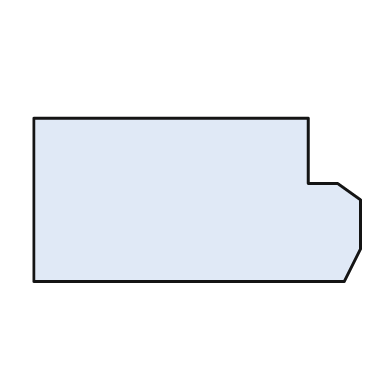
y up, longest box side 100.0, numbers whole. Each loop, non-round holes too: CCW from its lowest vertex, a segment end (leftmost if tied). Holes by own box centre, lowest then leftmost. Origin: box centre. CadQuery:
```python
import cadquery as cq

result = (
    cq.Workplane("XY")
    .moveTo(-50.0, -25.0)
    .lineTo(45.0, -25.0)
    .lineTo(50.0, -15.0)
    .lineTo(50.0, 0.0)
    .lineTo(43.0, 5.0)
    .lineTo(34.0, 5.0)
    .lineTo(34.0, 25.0)
    .lineTo(-50.0, 25.0)
    .close()
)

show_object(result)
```